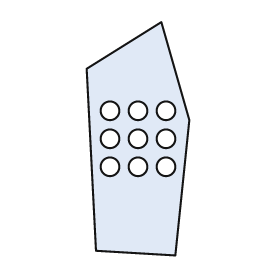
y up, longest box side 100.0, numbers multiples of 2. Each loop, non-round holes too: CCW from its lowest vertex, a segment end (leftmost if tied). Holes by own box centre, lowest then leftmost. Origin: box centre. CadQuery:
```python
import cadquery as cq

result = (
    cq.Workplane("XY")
    .moveTo(16.0, -50.0)
    .lineTo(22.0, 8.0)
    .lineTo(10.0, 50.0)
    .lineTo(-22.0, 30.0)
    .lineTo(-18.0, -48.0)
    .close()
    .moveTo(-12.0, -12.0)
    .circle(4.0)
    .moveTo(0.0, -12.0)
    .circle(4.0)
    .moveTo(12.0, -12.0)
    .circle(4.0)
    .moveTo(-12.0, 0.0)
    .circle(4.0)
    .moveTo(0.0, 0.0)
    .circle(4.0)
    .moveTo(12.0, 0.0)
    .circle(4.0)
    .moveTo(-12.0, 12.0)
    .circle(4.0)
    .moveTo(0.0, 12.0)
    .circle(4.0)
    .moveTo(12.0, 12.0)
    .circle(4.0)
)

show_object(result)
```